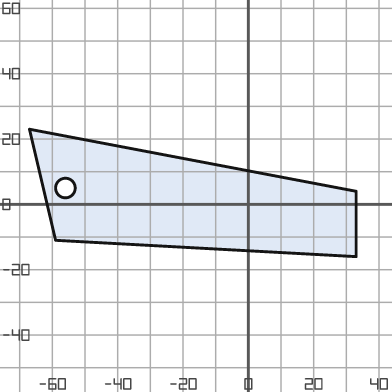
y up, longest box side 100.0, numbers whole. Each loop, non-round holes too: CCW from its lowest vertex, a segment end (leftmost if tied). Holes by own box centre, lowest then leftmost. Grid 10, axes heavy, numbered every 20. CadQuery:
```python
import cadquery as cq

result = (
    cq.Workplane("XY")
    .moveTo(33.0, -16.0)
    .lineTo(33.0, 4.0)
    .lineTo(-67.0, 23.0)
    .lineTo(-59.0, -11.0)
    .close()
    .moveTo(-56.0, 5.0)
    .circle(3.0)
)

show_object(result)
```